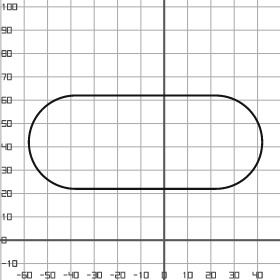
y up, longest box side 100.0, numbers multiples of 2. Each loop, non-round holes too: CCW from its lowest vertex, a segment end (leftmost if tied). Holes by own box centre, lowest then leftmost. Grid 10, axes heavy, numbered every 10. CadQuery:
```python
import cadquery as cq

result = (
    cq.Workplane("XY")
    .moveTo(-38.0, 22.0)
    .lineTo(22.0, 22.0)
    .threePointArc((42.0, 42.0), (22.0, 62.0))
    .lineTo(-38.0, 62.0)
    .threePointArc((-58.0, 42.0), (-38.0, 22.0))
    .close()
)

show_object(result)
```